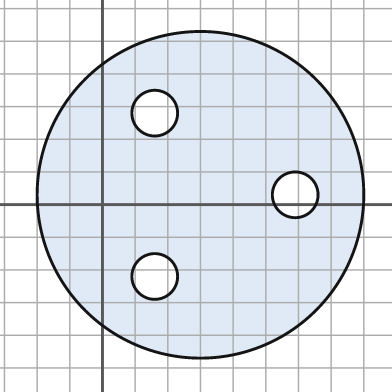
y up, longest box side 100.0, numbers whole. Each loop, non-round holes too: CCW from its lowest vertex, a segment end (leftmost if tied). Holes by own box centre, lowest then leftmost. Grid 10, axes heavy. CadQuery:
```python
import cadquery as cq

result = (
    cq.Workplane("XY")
    .moveTo(30.0, 3.0)
    .circle(50.0)
    .moveTo(16.0, -22.0)
    .circle(7.0)
    .moveTo(59.0, 3.0)
    .circle(7.0)
    .moveTo(16.0, 28.0)
    .circle(7.0)
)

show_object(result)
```